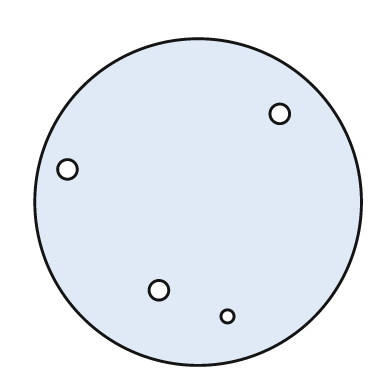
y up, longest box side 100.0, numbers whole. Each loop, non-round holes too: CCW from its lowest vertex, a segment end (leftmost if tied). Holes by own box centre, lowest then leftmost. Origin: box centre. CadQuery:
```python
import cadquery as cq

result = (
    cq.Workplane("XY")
    .moveTo(0.0, 0.0)
    .circle(50.0)
    .moveTo(9.0, -35.0)
    .circle(2.0)
    .moveTo(-12.0, -27.0)
    .circle(3.0)
    .moveTo(-40.0, 10.0)
    .circle(3.0)
    .moveTo(25.0, 27.0)
    .circle(3.0)
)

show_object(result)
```